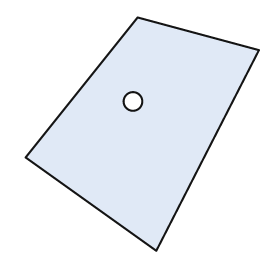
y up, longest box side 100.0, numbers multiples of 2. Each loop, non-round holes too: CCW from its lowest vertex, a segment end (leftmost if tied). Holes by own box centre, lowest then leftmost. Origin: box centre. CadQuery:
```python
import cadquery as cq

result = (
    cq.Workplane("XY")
    .moveTo(6.0, -50.0)
    .lineTo(50.0, 36.0)
    .lineTo(-2.0, 50.0)
    .lineTo(-50.0, -10.0)
    .close()
    .moveTo(-4.0, 14.0)
    .circle(4.0)
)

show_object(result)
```